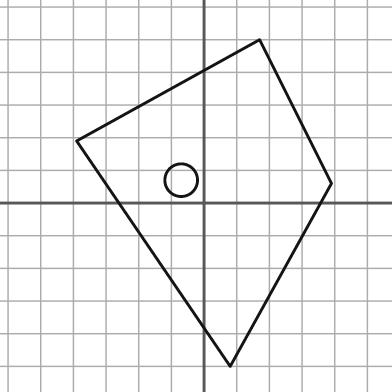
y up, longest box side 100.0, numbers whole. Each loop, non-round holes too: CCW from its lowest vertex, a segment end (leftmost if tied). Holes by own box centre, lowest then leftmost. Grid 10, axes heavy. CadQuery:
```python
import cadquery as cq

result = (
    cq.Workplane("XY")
    .moveTo(8.0, -50.0)
    .lineTo(39.0, 6.0)
    .lineTo(17.0, 50.0)
    .lineTo(-39.0, 19.0)
    .close()
    .moveTo(-7.0, 7.0)
    .circle(5.0)
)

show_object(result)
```